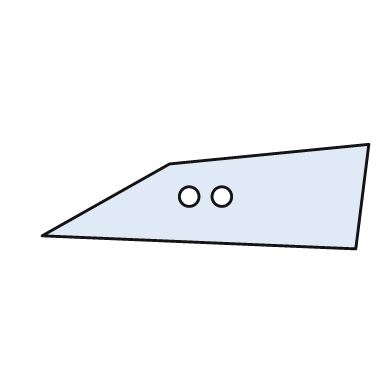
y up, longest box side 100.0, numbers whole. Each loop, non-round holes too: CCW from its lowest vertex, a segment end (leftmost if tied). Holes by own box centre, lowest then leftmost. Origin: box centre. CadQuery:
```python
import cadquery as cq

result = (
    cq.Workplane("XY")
    .moveTo(46.0, -16.0)
    .lineTo(50.0, 16.0)
    .lineTo(-11.0, 10.0)
    .lineTo(-50.0, -12.0)
    .close()
    .moveTo(-5.0, 0.0)
    .circle(3.0)
    .moveTo(5.0, 0.0)
    .circle(3.0)
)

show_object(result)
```